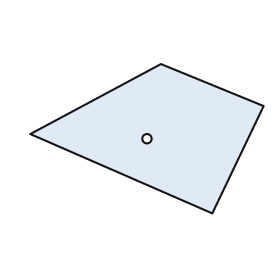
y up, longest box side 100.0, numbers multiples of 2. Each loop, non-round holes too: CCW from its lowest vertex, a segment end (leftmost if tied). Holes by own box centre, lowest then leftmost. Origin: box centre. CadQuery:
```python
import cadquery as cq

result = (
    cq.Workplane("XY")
    .moveTo(28.0, -32.0)
    .lineTo(50.0, 14.0)
    .lineTo(6.0, 32.0)
    .lineTo(-50.0, 2.0)
    .close()
    .moveTo(0.0, 0.0)
    .circle(2.0)
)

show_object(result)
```